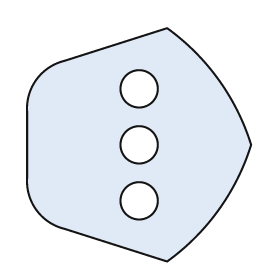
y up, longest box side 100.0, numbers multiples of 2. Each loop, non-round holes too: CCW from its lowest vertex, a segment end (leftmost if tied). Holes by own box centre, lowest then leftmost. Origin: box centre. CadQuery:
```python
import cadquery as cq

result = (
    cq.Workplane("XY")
    .moveTo(12.0, -50.0)
    .threePointArc((34.0, -28.0), (48.0, 0.0))
    .threePointArc((34.0, 28.0), (12.0, 50.0))
    .lineTo(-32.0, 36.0)
    .threePointArc((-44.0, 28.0), (-48.0, 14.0))
    .lineTo(-48.0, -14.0)
    .threePointArc((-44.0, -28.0), (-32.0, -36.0))
    .close()
    .moveTo(0.0, -24.0)
    .circle(8.0)
    .moveTo(0.0, 0.0)
    .circle(8.0)
    .moveTo(0.0, 24.0)
    .circle(8.0)
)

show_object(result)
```